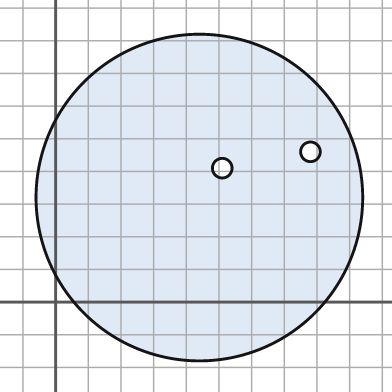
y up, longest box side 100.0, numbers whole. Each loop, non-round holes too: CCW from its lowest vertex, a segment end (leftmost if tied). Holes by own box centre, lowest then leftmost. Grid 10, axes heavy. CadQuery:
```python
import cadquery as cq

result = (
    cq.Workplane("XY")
    .moveTo(44.0, 32.0)
    .circle(50.0)
    .moveTo(51.0, 41.0)
    .circle(3.0)
    .moveTo(78.0, 46.0)
    .circle(3.0)
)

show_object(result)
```